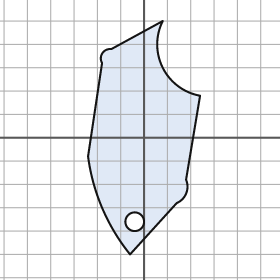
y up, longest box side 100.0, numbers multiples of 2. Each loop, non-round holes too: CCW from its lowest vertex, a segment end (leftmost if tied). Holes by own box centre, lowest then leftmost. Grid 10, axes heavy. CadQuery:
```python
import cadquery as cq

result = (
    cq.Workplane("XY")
    .moveTo(-6.0, -50.0)
    .lineTo(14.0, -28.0)
    .threePointArc((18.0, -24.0), (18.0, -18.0))
    .lineTo(24.0, 18.0)
    .threePointArc((8.0, 30.0), (8.0, 50.0))
    .lineTo(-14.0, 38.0)
    .threePointArc((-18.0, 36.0), (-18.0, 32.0))
    .lineTo(-24.0, -8.0)
    .threePointArc((-18.0, -30.0), (-6.0, -50.0))
    .close()
    .moveTo(-4.0, -36.0)
    .circle(4.0)
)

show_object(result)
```